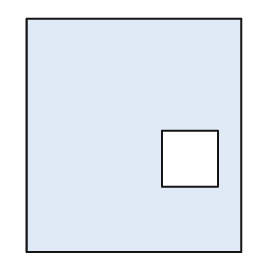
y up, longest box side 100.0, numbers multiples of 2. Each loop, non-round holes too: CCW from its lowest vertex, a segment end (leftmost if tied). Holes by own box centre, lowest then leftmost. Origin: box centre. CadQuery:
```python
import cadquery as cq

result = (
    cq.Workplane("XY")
    .moveTo(-46.0, -50.0)
    .lineTo(46.0, -50.0)
    .lineTo(46.0, 50.0)
    .lineTo(-46.0, 50.0)
    .close()
    .moveTo(12.0, -22.0)
    .lineTo(36.0, -22.0)
    .lineTo(36.0, 2.0)
    .lineTo(12.0, 2.0)
    .close()
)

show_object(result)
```